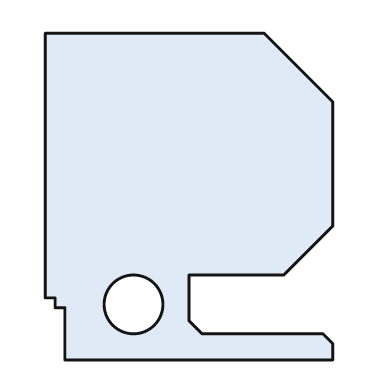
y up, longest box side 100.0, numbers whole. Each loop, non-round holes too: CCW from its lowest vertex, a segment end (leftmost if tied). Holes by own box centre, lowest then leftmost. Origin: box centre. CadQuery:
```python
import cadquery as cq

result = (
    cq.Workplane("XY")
    .moveTo(-38.0, -50.0)
    .lineTo(44.0, -50.0)
    .lineTo(44.0, -45.0)
    .lineTo(41.0, -42.0)
    .lineTo(4.0, -42.0)
    .lineTo(0.0, -38.0)
    .lineTo(0.0, -24.0)
    .lineTo(29.0, -24.0)
    .lineTo(44.0, -9.0)
    .lineTo(44.0, 29.0)
    .lineTo(23.0, 50.0)
    .lineTo(-44.0, 50.0)
    .lineTo(-44.0, -31.0)
    .lineTo(-41.0, -31.0)
    .lineTo(-41.0, -34.0)
    .lineTo(-38.0, -34.0)
    .close()
    .moveTo(-17.0, -33.0)
    .circle(9.0)
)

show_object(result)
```